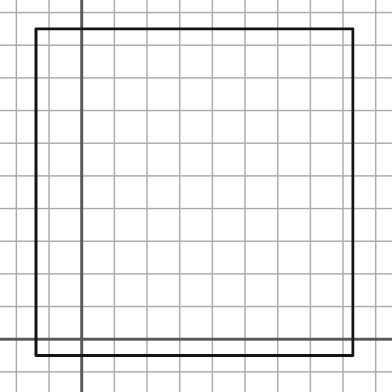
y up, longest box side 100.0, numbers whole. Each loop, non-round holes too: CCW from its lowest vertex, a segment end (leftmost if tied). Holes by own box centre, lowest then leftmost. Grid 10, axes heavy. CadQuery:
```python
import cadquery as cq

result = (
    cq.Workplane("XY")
    .moveTo(-14.0, -5.0)
    .lineTo(83.0, -5.0)
    .lineTo(83.0, 95.0)
    .lineTo(-14.0, 95.0)
    .close()
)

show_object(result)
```